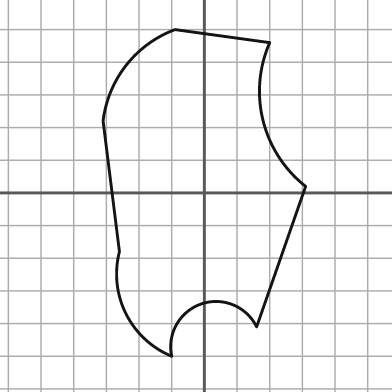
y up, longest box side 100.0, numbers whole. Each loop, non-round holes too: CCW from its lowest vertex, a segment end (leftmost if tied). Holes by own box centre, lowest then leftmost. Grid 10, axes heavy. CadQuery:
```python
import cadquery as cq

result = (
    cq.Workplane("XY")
    .moveTo(-10.0, -50.0)
    .threePointArc((-1.0, -34.0), (16.0, -41.0))
    .lineTo(31.0, 2.0)
    .threePointArc((18.0, 22.0), (20.0, 46.0))
    .lineTo(-9.0, 50.0)
    .threePointArc((-24.0, 39.0), (-31.0, 22.0))
    .lineTo(-26.0, -18.0)
    .threePointArc((-24.0, -37.0), (-10.0, -50.0))
    .close()
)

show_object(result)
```